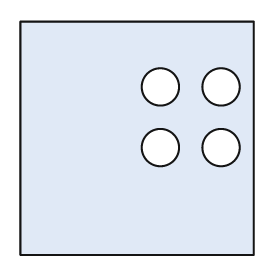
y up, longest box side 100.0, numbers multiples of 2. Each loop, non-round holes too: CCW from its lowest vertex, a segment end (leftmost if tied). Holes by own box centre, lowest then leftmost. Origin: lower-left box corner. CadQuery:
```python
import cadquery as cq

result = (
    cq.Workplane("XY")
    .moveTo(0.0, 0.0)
    .lineTo(100.0, 0.0)
    .lineTo(100.0, 100.0)
    .lineTo(0.0, 100.0)
    .close()
    .moveTo(60.0, 46.0)
    .circle(8.0)
    .moveTo(86.0, 46.0)
    .circle(8.0)
    .moveTo(60.0, 72.0)
    .circle(8.0)
    .moveTo(86.0, 72.0)
    .circle(8.0)
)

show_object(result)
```